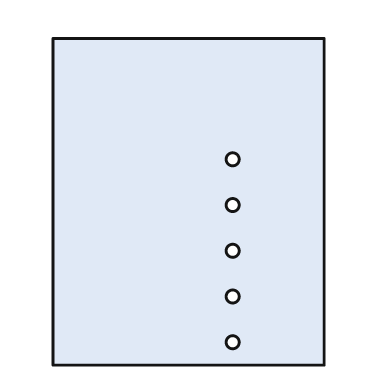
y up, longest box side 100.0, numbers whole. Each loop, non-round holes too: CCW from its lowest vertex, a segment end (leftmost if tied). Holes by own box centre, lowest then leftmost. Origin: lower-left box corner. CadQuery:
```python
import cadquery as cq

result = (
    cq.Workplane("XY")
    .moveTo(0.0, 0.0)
    .lineTo(83.0, 0.0)
    .lineTo(83.0, 100.0)
    .lineTo(0.0, 100.0)
    .close()
    .moveTo(55.0, 7.0)
    .circle(2.0)
    .moveTo(55.0, 21.0)
    .circle(2.0)
    .moveTo(55.0, 35.0)
    .circle(2.0)
    .moveTo(55.0, 49.0)
    .circle(2.0)
    .moveTo(55.0, 63.0)
    .circle(2.0)
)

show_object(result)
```